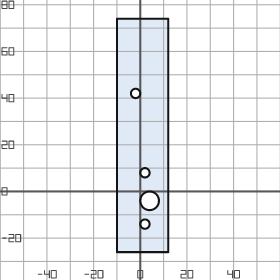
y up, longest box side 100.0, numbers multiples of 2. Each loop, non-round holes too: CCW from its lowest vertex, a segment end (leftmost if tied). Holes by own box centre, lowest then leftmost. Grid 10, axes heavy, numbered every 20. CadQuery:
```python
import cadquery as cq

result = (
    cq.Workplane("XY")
    .moveTo(-10.0, -26.0)
    .lineTo(12.0, -26.0)
    .lineTo(12.0, 74.0)
    .lineTo(-10.0, 74.0)
    .close()
    .moveTo(2.0, -14.0)
    .circle(2.0)
    .moveTo(4.0, -4.0)
    .circle(4.0)
    .moveTo(2.0, 8.0)
    .circle(2.0)
    .moveTo(-2.0, 42.0)
    .circle(2.0)
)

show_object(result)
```